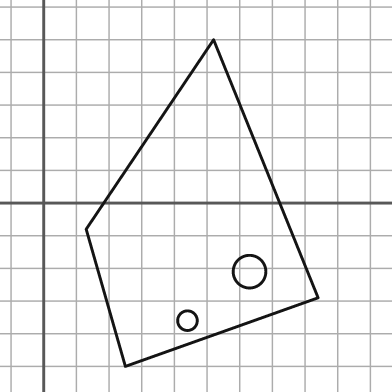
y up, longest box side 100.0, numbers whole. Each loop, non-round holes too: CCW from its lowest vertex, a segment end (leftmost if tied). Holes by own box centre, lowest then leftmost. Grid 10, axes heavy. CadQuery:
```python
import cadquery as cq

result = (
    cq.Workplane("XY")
    .moveTo(25.0, -50.0)
    .lineTo(84.0, -29.0)
    .lineTo(52.0, 50.0)
    .lineTo(13.0, -8.0)
    .close()
    .moveTo(44.0, -36.0)
    .circle(3.0)
    .moveTo(63.0, -21.0)
    .circle(5.0)
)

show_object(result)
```